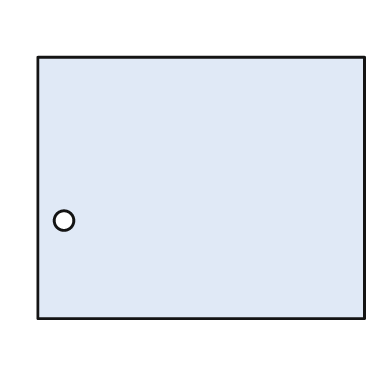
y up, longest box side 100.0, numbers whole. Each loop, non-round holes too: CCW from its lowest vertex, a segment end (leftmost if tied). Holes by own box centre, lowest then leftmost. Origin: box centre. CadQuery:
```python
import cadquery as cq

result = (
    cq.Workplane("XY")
    .moveTo(-50.0, -40.0)
    .lineTo(50.0, -40.0)
    .lineTo(50.0, 40.0)
    .lineTo(-50.0, 40.0)
    .close()
    .moveTo(-42.0, -10.0)
    .circle(3.0)
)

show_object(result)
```